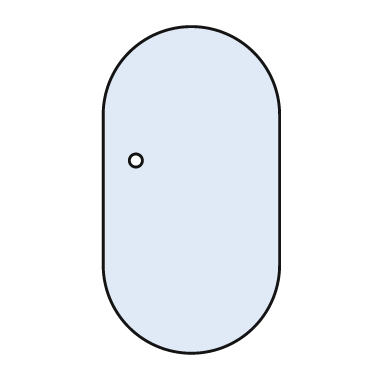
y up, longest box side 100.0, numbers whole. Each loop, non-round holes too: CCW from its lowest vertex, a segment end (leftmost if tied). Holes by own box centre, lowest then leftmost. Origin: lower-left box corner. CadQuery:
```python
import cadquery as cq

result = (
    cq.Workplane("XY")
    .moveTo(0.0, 27.0)
    .threePointArc((27.0, 0.0), (54.0, 27.0))
    .lineTo(54.0, 73.0)
    .threePointArc((27.0, 100.0), (0.0, 73.0))
    .close()
    .moveTo(10.0, 59.0)
    .circle(2.0)
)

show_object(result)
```